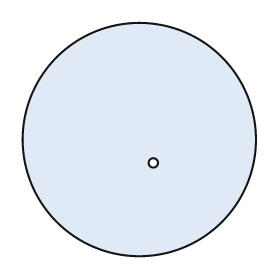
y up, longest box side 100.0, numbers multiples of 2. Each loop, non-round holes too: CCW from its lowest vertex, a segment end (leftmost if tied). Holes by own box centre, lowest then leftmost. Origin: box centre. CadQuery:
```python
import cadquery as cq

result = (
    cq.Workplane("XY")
    .moveTo(0.0, 0.0)
    .circle(50.0)
    .moveTo(6.0, -10.0)
    .circle(2.0)
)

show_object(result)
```